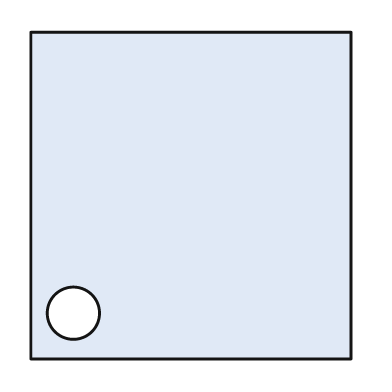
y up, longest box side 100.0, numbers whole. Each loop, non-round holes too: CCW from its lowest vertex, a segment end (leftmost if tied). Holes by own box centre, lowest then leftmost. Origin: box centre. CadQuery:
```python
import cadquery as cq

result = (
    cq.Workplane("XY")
    .moveTo(-49.0, -50.0)
    .lineTo(49.0, -50.0)
    .lineTo(49.0, 50.0)
    .lineTo(-49.0, 50.0)
    .close()
    .moveTo(-36.0, -36.0)
    .circle(8.0)
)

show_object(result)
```